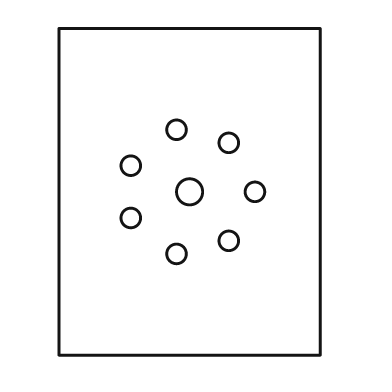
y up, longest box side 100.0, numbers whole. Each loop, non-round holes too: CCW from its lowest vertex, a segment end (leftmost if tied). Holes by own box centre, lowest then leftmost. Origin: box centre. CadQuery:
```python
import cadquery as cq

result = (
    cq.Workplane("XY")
    .moveTo(-40.0, -50.0)
    .lineTo(40.0, -50.0)
    .lineTo(40.0, 50.0)
    .lineTo(-40.0, 50.0)
    .close()
    .moveTo(-4.0, -19.0)
    .circle(3.0)
    .moveTo(12.0, -15.0)
    .circle(3.0)
    .moveTo(-18.0, -8.0)
    .circle(3.0)
    .moveTo(0.0, 0.0)
    .circle(4.0)
    .moveTo(20.0, 0.0)
    .circle(3.0)
    .moveTo(-18.0, 8.0)
    .circle(3.0)
    .moveTo(12.0, 15.0)
    .circle(3.0)
    .moveTo(-4.0, 19.0)
    .circle(3.0)
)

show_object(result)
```